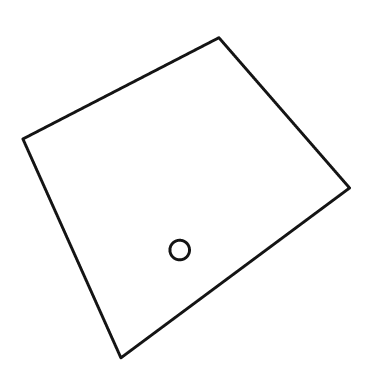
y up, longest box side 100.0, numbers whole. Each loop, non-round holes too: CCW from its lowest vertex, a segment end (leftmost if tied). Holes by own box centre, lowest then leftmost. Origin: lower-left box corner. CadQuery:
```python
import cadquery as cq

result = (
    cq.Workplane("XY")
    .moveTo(30.0, 0.0)
    .lineTo(100.0, 52.0)
    .lineTo(60.0, 98.0)
    .lineTo(0.0, 67.0)
    .close()
    .moveTo(48.0, 33.0)
    .circle(3.0)
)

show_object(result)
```